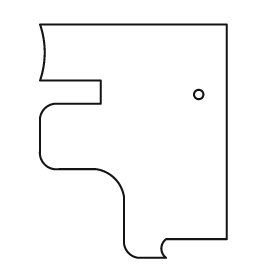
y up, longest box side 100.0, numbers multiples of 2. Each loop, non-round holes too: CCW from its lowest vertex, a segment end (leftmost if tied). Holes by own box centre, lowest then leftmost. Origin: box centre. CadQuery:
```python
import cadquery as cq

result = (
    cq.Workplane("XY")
    .moveTo(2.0, -50.0)
    .lineTo(14.0, -50.0)
    .threePointArc((12.0, -46.0), (14.0, -42.0))
    .lineTo(40.0, -42.0)
    .lineTo(40.0, 50.0)
    .lineTo(-40.0, 50.0)
    .threePointArc((-38.0, 38.0), (-40.0, 26.0))
    .lineTo(-14.0, 26.0)
    .lineTo(-14.0, 16.0)
    .lineTo(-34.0, 16.0)
    .threePointArc((-38.0, 14.0), (-40.0, 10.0))
    .lineTo(-40.0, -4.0)
    .threePointArc((-38.0, -10.0), (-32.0, -12.0))
    .lineTo(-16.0, -12.0)
    .threePointArc((-8.0, -16.0), (-4.0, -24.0))
    .lineTo(-4.0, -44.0)
    .threePointArc((-2.0, -48.0), (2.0, -50.0))
    .close()
    .moveTo(28.0, 20.0)
    .circle(2.0)
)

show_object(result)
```